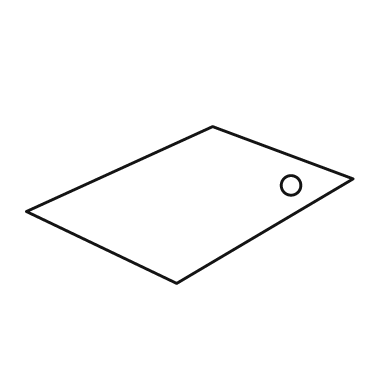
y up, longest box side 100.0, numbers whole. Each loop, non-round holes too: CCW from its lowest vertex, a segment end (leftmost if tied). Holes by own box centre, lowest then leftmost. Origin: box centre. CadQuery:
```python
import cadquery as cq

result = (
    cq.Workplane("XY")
    .moveTo(-4.0, -24.0)
    .lineTo(50.0, 8.0)
    .lineTo(7.0, 24.0)
    .lineTo(-50.0, -2.0)
    .close()
    .moveTo(31.0, 6.0)
    .circle(3.0)
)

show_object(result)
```